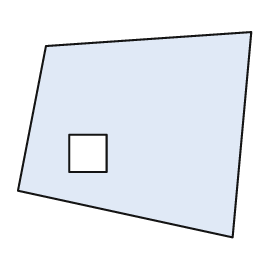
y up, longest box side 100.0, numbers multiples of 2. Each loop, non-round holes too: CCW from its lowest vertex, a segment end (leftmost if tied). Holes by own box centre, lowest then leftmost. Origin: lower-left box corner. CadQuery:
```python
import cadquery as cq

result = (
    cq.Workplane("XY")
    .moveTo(92.0, 0.0)
    .lineTo(100.0, 88.0)
    .lineTo(12.0, 82.0)
    .lineTo(0.0, 20.0)
    .close()
    .moveTo(22.0, 28.0)
    .lineTo(38.0, 28.0)
    .lineTo(38.0, 44.0)
    .lineTo(22.0, 44.0)
    .close()
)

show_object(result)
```